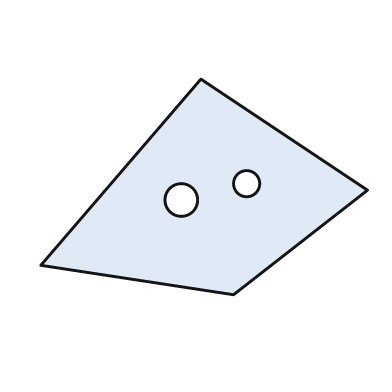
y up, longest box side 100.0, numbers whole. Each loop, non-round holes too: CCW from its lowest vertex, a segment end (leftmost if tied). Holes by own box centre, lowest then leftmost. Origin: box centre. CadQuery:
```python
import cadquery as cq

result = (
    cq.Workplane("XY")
    .moveTo(9.0, -33.0)
    .lineTo(50.0, -1.0)
    .lineTo(-1.0, 33.0)
    .lineTo(-50.0, -24.0)
    .close()
    .moveTo(-7.0, -4.0)
    .circle(5.0)
    .moveTo(13.0, 1.0)
    .circle(4.0)
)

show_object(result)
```